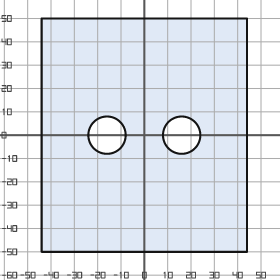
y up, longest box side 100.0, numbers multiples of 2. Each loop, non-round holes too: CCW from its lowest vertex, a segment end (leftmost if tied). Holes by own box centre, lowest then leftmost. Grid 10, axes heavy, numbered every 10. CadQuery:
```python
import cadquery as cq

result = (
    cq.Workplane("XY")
    .moveTo(-44.0, -50.0)
    .lineTo(44.0, -50.0)
    .lineTo(44.0, 50.0)
    .lineTo(-44.0, 50.0)
    .close()
    .moveTo(-16.0, 0.0)
    .circle(8.0)
    .moveTo(16.0, 0.0)
    .circle(8.0)
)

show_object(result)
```